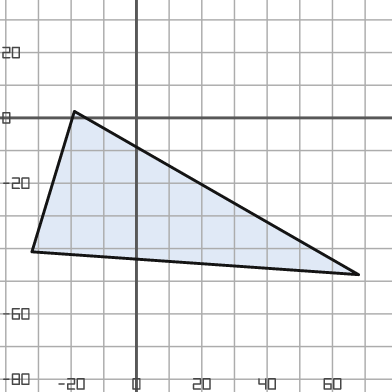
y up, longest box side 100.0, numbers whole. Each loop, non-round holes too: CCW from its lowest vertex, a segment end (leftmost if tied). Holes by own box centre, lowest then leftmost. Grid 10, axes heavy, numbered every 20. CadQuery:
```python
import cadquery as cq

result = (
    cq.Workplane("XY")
    .moveTo(68.0, -48.0)
    .lineTo(-19.0, 2.0)
    .lineTo(-32.0, -41.0)
    .close()
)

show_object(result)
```